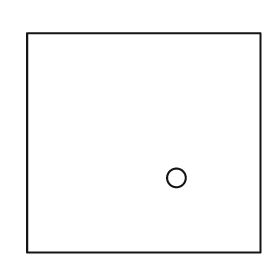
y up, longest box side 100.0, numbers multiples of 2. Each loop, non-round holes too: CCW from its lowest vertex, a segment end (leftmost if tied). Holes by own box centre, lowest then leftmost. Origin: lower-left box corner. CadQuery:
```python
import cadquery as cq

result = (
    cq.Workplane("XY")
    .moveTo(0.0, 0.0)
    .lineTo(100.0, 0.0)
    .lineTo(100.0, 94.0)
    .lineTo(0.0, 94.0)
    .close()
    .moveTo(64.0, 32.0)
    .circle(4.0)
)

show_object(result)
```